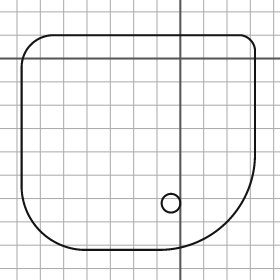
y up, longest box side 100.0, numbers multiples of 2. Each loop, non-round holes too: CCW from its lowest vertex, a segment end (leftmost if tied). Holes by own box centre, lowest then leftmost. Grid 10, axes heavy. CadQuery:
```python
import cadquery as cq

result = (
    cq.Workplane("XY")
    .moveTo(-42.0, -82.0)
    .lineTo(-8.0, -82.0)
    .threePointArc((20.0, -70.0), (32.0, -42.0))
    .lineTo(32.0, 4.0)
    .threePointArc((30.0, 8.0), (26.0, 10.0))
    .lineTo(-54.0, 10.0)
    .threePointArc((-64.0, 6.0), (-68.0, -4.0))
    .lineTo(-68.0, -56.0)
    .threePointArc((-60.0, -74.0), (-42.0, -82.0))
    .close()
    .moveTo(-4.0, -62.0)
    .circle(4.0)
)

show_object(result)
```